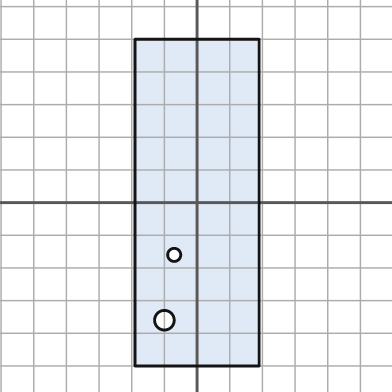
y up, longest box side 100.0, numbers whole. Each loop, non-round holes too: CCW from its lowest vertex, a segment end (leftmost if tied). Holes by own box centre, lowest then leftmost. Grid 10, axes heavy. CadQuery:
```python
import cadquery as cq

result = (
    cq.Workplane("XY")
    .moveTo(-19.0, -50.0)
    .lineTo(19.0, -50.0)
    .lineTo(19.0, 50.0)
    .lineTo(-19.0, 50.0)
    .close()
    .moveTo(-10.0, -36.0)
    .circle(3.0)
    .moveTo(-7.0, -16.0)
    .circle(2.0)
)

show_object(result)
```